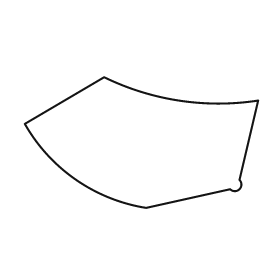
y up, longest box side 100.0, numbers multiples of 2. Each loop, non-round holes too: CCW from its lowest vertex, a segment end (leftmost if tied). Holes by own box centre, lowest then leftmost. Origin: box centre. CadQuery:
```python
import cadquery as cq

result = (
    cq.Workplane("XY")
    .moveTo(2.0, -28.0)
    .lineTo(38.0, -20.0)
    .threePointArc((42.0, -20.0), (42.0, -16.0))
    .lineTo(50.0, 18.0)
    .threePointArc((16.0, 18.0), (-16.0, 28.0))
    .lineTo(-50.0, 8.0)
    .threePointArc((-28.0, -16.0), (2.0, -28.0))
    .close()
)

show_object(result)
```